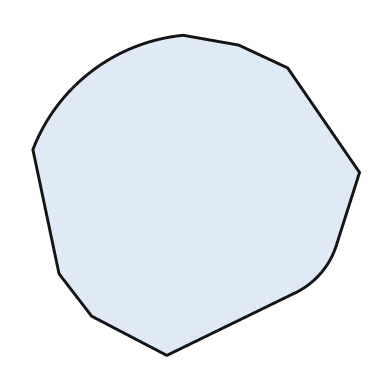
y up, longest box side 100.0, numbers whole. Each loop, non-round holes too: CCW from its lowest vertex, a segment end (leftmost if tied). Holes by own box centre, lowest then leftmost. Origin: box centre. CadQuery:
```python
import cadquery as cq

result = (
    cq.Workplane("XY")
    .moveTo(-9.0, -49.0)
    .lineTo(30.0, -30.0)
    .threePointArc((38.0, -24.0), (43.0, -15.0))
    .lineTo(50.0, 7.0)
    .lineTo(28.0, 39.0)
    .lineTo(13.0, 46.0)
    .lineTo(-4.0, 49.0)
    .threePointArc((-32.0, 38.0), (-50.0, 14.0))
    .lineTo(-42.0, -24.0)
    .lineTo(-32.0, -37.0)
    .close()
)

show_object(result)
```